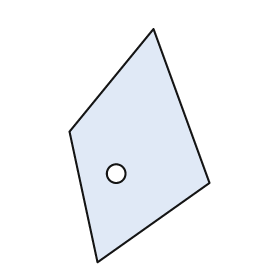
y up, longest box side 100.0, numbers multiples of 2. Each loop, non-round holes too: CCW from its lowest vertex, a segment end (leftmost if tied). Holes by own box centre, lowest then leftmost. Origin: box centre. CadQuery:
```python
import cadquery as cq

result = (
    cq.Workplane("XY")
    .moveTo(-18.0, -50.0)
    .lineTo(30.0, -16.0)
    .lineTo(6.0, 50.0)
    .lineTo(-30.0, 6.0)
    .close()
    .moveTo(-10.0, -12.0)
    .circle(4.0)
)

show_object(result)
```